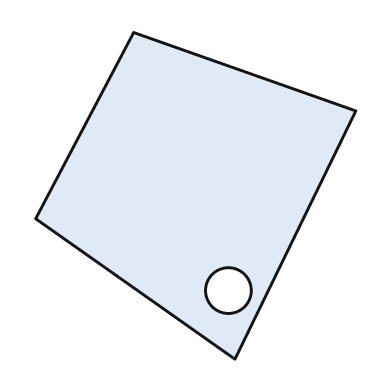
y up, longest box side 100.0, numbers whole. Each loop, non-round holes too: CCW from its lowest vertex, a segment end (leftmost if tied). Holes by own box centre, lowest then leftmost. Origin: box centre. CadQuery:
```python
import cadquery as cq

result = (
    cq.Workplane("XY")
    .moveTo(12.0, -50.0)
    .lineTo(49.0, 26.0)
    .lineTo(-19.0, 50.0)
    .lineTo(-49.0, -7.0)
    .close()
    .moveTo(10.0, -29.0)
    .circle(7.0)
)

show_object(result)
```